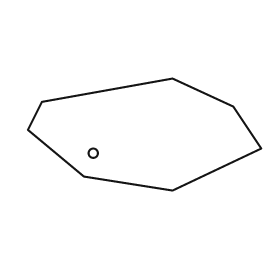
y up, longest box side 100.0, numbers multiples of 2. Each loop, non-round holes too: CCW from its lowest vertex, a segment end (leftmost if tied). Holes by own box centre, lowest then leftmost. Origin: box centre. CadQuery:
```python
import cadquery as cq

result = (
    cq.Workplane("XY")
    .moveTo(12.0, -24.0)
    .lineTo(50.0, -6.0)
    .lineTo(38.0, 12.0)
    .lineTo(12.0, 24.0)
    .lineTo(-44.0, 14.0)
    .lineTo(-50.0, 2.0)
    .lineTo(-26.0, -18.0)
    .close()
    .moveTo(-22.0, -8.0)
    .circle(2.0)
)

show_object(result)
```